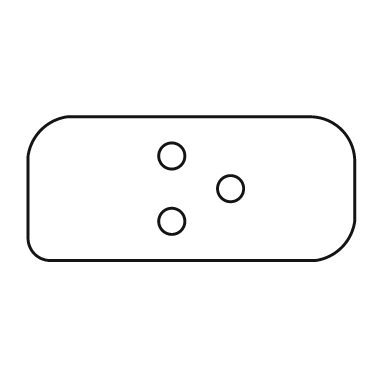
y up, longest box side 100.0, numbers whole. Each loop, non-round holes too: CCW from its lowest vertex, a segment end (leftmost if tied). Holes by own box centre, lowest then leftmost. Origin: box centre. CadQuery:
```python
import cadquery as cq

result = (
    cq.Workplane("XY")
    .moveTo(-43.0, -22.0)
    .lineTo(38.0, -22.0)
    .threePointArc((46.0, -18.0), (50.0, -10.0))
    .lineTo(50.0, 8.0)
    .threePointArc((46.0, 18.0), (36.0, 22.0))
    .lineTo(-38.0, 22.0)
    .threePointArc((-46.0, 18.0), (-50.0, 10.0))
    .lineTo(-50.0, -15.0)
    .threePointArc((-48.0, -20.0), (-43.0, -22.0))
    .close()
    .moveTo(-6.0, -10.0)
    .circle(4.0)
    .moveTo(12.0, 0.0)
    .circle(4.0)
    .moveTo(-6.0, 10.0)
    .circle(4.0)
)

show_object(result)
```